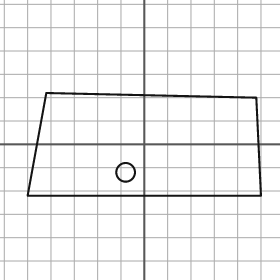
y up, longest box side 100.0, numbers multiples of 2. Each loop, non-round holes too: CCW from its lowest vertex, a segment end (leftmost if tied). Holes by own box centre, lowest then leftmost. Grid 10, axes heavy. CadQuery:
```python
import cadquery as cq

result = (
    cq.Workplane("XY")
    .moveTo(-50.0, -22.0)
    .lineTo(50.0, -22.0)
    .lineTo(48.0, 20.0)
    .lineTo(-42.0, 22.0)
    .close()
    .moveTo(-8.0, -12.0)
    .circle(4.0)
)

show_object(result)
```